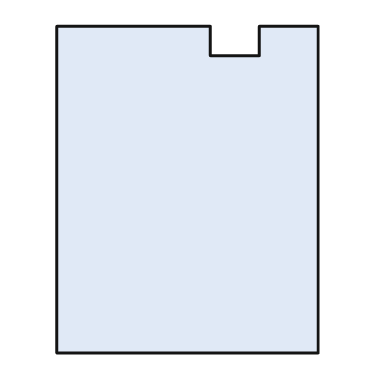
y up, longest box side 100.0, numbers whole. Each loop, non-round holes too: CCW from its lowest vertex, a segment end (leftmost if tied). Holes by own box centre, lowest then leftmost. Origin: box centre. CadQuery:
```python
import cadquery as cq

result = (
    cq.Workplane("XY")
    .moveTo(-40.0, -50.0)
    .lineTo(40.0, -50.0)
    .lineTo(40.0, 50.0)
    .lineTo(22.0, 50.0)
    .lineTo(22.0, 41.0)
    .lineTo(7.0, 41.0)
    .lineTo(7.0, 50.0)
    .lineTo(-40.0, 50.0)
    .close()
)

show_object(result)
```